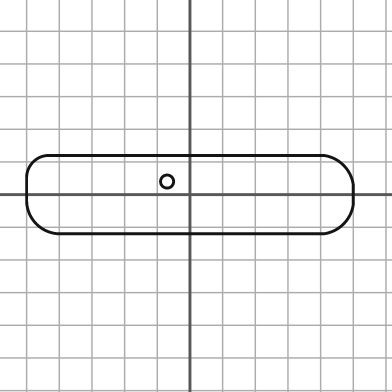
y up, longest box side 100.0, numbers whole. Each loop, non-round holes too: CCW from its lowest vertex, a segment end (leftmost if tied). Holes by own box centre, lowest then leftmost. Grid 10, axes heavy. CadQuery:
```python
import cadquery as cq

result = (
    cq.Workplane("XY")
    .moveTo(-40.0, -12.0)
    .lineTo(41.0, -12.0)
    .threePointArc((47.0, -9.0), (50.0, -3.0))
    .lineTo(50.0, 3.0)
    .threePointArc((47.0, 9.0), (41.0, 12.0))
    .lineTo(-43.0, 12.0)
    .threePointArc((-48.0, 10.0), (-50.0, 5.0))
    .lineTo(-50.0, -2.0)
    .threePointArc((-47.0, -9.0), (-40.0, -12.0))
    .close()
    .moveTo(-7.0, 4.0)
    .circle(2.0)
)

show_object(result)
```